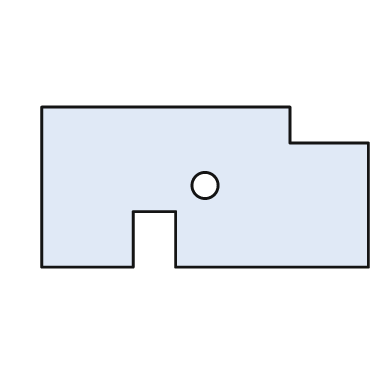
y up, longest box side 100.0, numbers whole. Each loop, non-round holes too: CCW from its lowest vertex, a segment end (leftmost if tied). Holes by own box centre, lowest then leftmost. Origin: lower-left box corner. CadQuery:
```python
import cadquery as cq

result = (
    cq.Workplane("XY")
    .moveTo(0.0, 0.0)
    .lineTo(28.0, 0.0)
    .lineTo(28.0, 17.0)
    .lineTo(41.0, 17.0)
    .lineTo(41.0, 0.0)
    .lineTo(100.0, 0.0)
    .lineTo(100.0, 38.0)
    .lineTo(76.0, 38.0)
    .lineTo(76.0, 49.0)
    .lineTo(0.0, 49.0)
    .close()
    .moveTo(50.0, 25.0)
    .circle(4.0)
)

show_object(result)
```